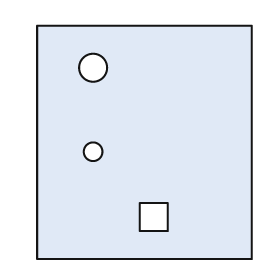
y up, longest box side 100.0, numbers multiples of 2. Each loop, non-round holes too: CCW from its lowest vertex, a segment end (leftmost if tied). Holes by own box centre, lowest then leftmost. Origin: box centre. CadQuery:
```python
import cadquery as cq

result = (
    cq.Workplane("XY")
    .moveTo(-46.0, -50.0)
    .lineTo(46.0, -50.0)
    .lineTo(46.0, 50.0)
    .lineTo(-46.0, 50.0)
    .close()
    .moveTo(-2.0, -38.0)
    .lineTo(10.0, -38.0)
    .lineTo(10.0, -26.0)
    .lineTo(-2.0, -26.0)
    .close()
    .moveTo(-22.0, -4.0)
    .circle(4.0)
    .moveTo(-22.0, 32.0)
    .circle(6.0)
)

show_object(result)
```